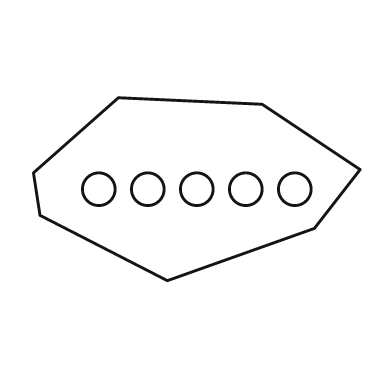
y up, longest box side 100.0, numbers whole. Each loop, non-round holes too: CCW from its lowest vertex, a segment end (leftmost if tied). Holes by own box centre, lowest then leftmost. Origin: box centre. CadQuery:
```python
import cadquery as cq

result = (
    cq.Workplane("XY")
    .moveTo(-9.0, -28.0)
    .lineTo(36.0, -12.0)
    .lineTo(50.0, 6.0)
    .lineTo(20.0, 26.0)
    .lineTo(-24.0, 28.0)
    .lineTo(-50.0, 5.0)
    .lineTo(-48.0, -8.0)
    .close()
    .moveTo(-30.0, 0.0)
    .circle(5.0)
    .moveTo(-15.0, 0.0)
    .circle(5.0)
    .moveTo(0.0, 0.0)
    .circle(5.0)
    .moveTo(15.0, 0.0)
    .circle(5.0)
    .moveTo(30.0, 0.0)
    .circle(5.0)
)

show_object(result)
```